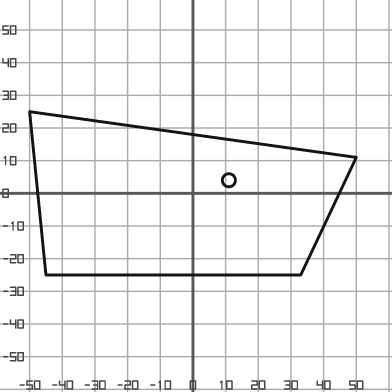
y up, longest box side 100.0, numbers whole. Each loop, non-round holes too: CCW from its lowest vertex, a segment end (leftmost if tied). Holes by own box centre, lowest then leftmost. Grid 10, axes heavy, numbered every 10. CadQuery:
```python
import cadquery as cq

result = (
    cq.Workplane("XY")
    .moveTo(-45.0, -25.0)
    .lineTo(33.0, -25.0)
    .lineTo(50.0, 11.0)
    .lineTo(-50.0, 25.0)
    .close()
    .moveTo(11.0, 4.0)
    .circle(2.0)
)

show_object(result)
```